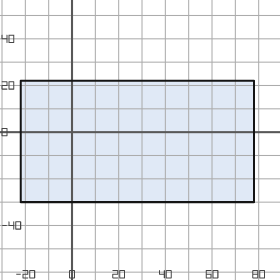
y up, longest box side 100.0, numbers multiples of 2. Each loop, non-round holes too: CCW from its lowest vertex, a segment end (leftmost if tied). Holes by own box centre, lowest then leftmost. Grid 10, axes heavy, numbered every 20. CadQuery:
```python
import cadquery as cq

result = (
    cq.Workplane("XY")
    .moveTo(-22.0, -30.0)
    .lineTo(78.0, -30.0)
    .lineTo(78.0, 22.0)
    .lineTo(-22.0, 22.0)
    .close()
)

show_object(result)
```